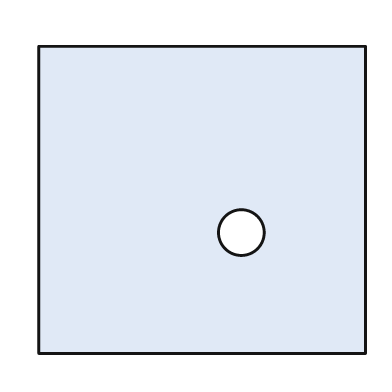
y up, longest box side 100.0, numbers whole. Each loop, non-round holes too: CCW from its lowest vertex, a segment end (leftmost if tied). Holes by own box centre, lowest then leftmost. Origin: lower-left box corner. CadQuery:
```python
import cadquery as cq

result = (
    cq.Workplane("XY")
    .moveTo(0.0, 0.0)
    .lineTo(100.0, 0.0)
    .lineTo(100.0, 94.0)
    .lineTo(0.0, 94.0)
    .close()
    .moveTo(62.0, 37.0)
    .circle(7.0)
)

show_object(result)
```